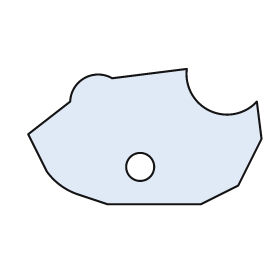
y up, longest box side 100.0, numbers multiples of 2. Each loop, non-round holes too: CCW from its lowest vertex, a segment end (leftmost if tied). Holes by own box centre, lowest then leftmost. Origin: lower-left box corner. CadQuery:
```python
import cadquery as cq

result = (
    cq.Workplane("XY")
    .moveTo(34.0, 0.0)
    .lineTo(74.0, 0.0)
    .lineTo(90.0, 8.0)
    .lineTo(100.0, 28.0)
    .lineTo(98.0, 44.0)
    .threePointArc((78.0, 40.0), (68.0, 58.0))
    .lineTo(36.0, 54.0)
    .threePointArc((24.0, 54.0), (18.0, 44.0))
    .lineTo(0.0, 30.0)
    .lineTo(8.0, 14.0)
    .threePointArc((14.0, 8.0), (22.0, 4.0))
    .close()
    .moveTo(48.0, 16.0)
    .circle(6.0)
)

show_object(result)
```